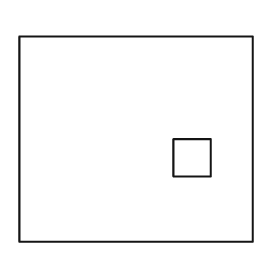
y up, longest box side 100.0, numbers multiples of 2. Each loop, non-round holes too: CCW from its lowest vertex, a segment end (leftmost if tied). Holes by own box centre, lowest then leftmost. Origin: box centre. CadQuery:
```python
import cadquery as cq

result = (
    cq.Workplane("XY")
    .moveTo(-50.0, -44.0)
    .lineTo(50.0, -44.0)
    .lineTo(50.0, 44.0)
    .lineTo(-50.0, 44.0)
    .close()
    .moveTo(16.0, -16.0)
    .lineTo(32.0, -16.0)
    .lineTo(32.0, 0.0)
    .lineTo(16.0, 0.0)
    .close()
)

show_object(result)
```